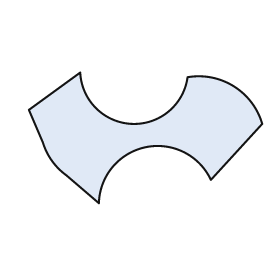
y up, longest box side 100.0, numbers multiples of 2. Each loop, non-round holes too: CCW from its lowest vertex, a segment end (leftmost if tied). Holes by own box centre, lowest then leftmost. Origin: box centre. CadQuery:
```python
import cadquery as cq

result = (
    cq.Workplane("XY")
    .moveTo(-20.0, -28.0)
    .threePointArc((0.0, -4.0), (28.0, -18.0))
    .lineTo(50.0, 6.0)
    .threePointArc((38.0, 22.0), (18.0, 26.0))
    .threePointArc((-6.0, 6.0), (-28.0, 28.0))
    .lineTo(-50.0, 12.0)
    .lineTo(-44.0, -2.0)
    .threePointArc((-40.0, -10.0), (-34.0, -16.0))
    .close()
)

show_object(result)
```